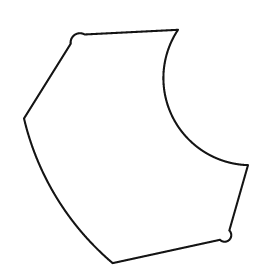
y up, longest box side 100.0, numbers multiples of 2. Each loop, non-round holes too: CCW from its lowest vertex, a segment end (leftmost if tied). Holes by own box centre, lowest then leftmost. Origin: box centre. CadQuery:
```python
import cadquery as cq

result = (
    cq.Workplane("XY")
    .moveTo(-10.0, -50.0)
    .lineTo(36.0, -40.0)
    .threePointArc((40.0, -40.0), (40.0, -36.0))
    .lineTo(48.0, -8.0)
    .threePointArc((16.0, 12.0), (18.0, 50.0))
    .lineTo(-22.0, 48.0)
    .threePointArc((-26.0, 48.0), (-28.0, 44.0))
    .lineTo(-48.0, 12.0)
    .threePointArc((-34.0, -22.0), (-10.0, -50.0))
    .close()
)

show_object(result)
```